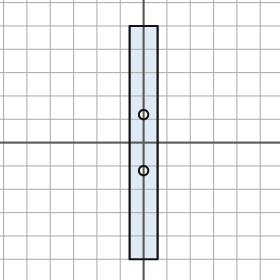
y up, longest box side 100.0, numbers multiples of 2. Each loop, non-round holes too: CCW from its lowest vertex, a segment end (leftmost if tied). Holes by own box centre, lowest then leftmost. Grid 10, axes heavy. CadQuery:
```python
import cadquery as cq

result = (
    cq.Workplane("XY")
    .moveTo(-6.0, -50.0)
    .lineTo(6.0, -50.0)
    .lineTo(6.0, 50.0)
    .lineTo(-6.0, 50.0)
    .close()
    .moveTo(0.0, -12.0)
    .circle(2.0)
    .moveTo(0.0, 12.0)
    .circle(2.0)
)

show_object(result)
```